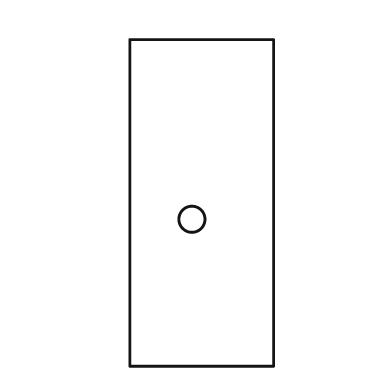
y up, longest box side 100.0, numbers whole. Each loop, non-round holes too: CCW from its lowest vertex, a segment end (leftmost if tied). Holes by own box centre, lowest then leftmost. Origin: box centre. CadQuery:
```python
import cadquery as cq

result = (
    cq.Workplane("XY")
    .moveTo(-22.0, -50.0)
    .lineTo(22.0, -50.0)
    .lineTo(22.0, 50.0)
    .lineTo(-22.0, 50.0)
    .close()
    .moveTo(-3.0, -5.0)
    .circle(4.0)
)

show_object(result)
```